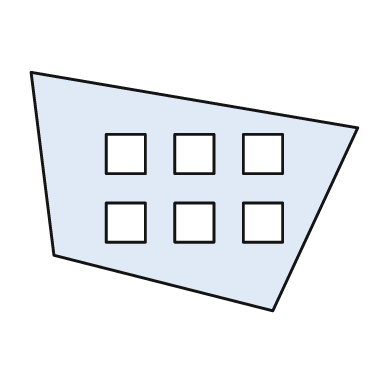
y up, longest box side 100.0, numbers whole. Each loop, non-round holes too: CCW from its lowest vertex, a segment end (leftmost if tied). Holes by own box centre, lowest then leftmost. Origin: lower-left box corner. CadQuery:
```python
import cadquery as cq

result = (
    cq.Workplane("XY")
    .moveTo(74.0, 0.0)
    .lineTo(100.0, 56.0)
    .lineTo(0.0, 73.0)
    .lineTo(7.0, 17.0)
    .close()
    .moveTo(23.0, 21.0)
    .lineTo(35.0, 21.0)
    .lineTo(35.0, 33.0)
    .lineTo(23.0, 33.0)
    .close()
    .moveTo(44.0, 21.0)
    .lineTo(56.0, 21.0)
    .lineTo(56.0, 33.0)
    .lineTo(44.0, 33.0)
    .close()
    .moveTo(65.0, 21.0)
    .lineTo(77.0, 21.0)
    .lineTo(77.0, 33.0)
    .lineTo(65.0, 33.0)
    .close()
    .moveTo(23.0, 42.0)
    .lineTo(35.0, 42.0)
    .lineTo(35.0, 54.0)
    .lineTo(23.0, 54.0)
    .close()
    .moveTo(44.0, 42.0)
    .lineTo(56.0, 42.0)
    .lineTo(56.0, 54.0)
    .lineTo(44.0, 54.0)
    .close()
    .moveTo(65.0, 42.0)
    .lineTo(77.0, 42.0)
    .lineTo(77.0, 54.0)
    .lineTo(65.0, 54.0)
    .close()
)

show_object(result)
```